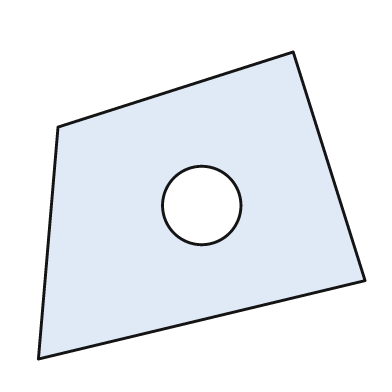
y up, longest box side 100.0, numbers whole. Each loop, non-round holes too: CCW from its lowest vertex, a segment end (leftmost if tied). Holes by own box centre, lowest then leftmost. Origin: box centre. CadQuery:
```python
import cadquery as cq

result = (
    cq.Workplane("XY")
    .moveTo(-50.0, -47.0)
    .lineTo(50.0, -23.0)
    .lineTo(28.0, 47.0)
    .lineTo(-44.0, 24.0)
    .close()
    .moveTo(0.0, 0.0)
    .circle(12.0)
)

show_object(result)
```